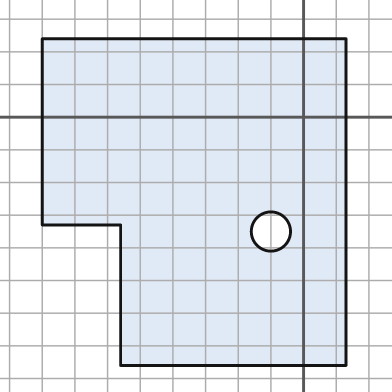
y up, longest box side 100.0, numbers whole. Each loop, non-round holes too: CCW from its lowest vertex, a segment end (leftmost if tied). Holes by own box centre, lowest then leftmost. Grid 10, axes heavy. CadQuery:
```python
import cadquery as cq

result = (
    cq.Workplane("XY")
    .moveTo(-56.0, -76.0)
    .lineTo(13.0, -76.0)
    .lineTo(13.0, 24.0)
    .lineTo(-80.0, 24.0)
    .lineTo(-80.0, -33.0)
    .lineTo(-56.0, -33.0)
    .close()
    .moveTo(-10.0, -35.0)
    .circle(6.0)
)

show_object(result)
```